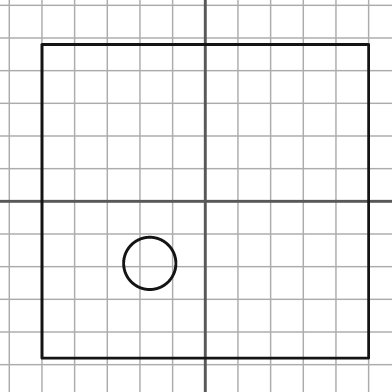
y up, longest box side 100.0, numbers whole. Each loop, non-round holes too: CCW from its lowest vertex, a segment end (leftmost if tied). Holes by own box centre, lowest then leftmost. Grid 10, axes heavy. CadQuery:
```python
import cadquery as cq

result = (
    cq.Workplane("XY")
    .moveTo(-50.0, -48.0)
    .lineTo(50.0, -48.0)
    .lineTo(50.0, 48.0)
    .lineTo(-50.0, 48.0)
    .close()
    .moveTo(-17.0, -19.0)
    .circle(8.0)
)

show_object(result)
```